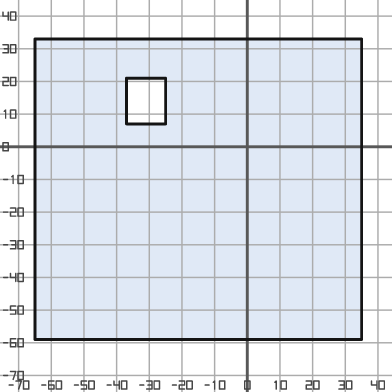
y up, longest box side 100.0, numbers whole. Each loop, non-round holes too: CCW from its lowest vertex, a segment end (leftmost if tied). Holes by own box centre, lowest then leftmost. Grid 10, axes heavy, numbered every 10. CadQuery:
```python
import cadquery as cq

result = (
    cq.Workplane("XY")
    .moveTo(-65.0, -59.0)
    .lineTo(35.0, -59.0)
    .lineTo(35.0, 33.0)
    .lineTo(-65.0, 33.0)
    .close()
    .moveTo(-37.0, 7.0)
    .lineTo(-25.0, 7.0)
    .lineTo(-25.0, 21.0)
    .lineTo(-37.0, 21.0)
    .close()
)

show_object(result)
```